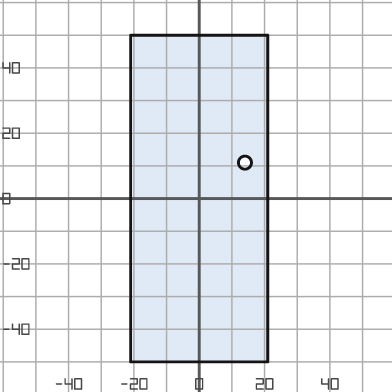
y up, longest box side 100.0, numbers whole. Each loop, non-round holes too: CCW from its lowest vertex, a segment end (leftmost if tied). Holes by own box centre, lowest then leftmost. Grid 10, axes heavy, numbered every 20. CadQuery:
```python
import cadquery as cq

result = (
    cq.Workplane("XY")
    .moveTo(-21.0, -50.0)
    .lineTo(21.0, -50.0)
    .lineTo(21.0, 50.0)
    .lineTo(-21.0, 50.0)
    .close()
    .moveTo(14.0, 11.0)
    .circle(2.0)
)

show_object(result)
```